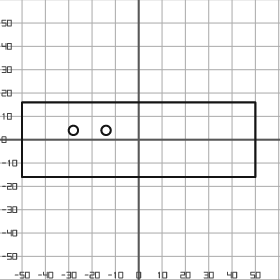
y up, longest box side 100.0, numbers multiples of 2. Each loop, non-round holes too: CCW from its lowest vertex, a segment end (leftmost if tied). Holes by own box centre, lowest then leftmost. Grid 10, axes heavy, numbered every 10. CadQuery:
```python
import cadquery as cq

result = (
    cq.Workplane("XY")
    .moveTo(-50.0, -16.0)
    .lineTo(50.0, -16.0)
    .lineTo(50.0, 16.0)
    .lineTo(-50.0, 16.0)
    .close()
    .moveTo(-28.0, 4.0)
    .circle(2.0)
    .moveTo(-14.0, 4.0)
    .circle(2.0)
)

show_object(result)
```